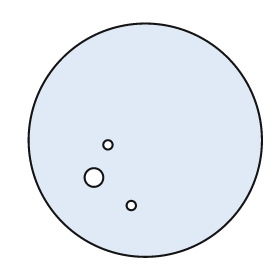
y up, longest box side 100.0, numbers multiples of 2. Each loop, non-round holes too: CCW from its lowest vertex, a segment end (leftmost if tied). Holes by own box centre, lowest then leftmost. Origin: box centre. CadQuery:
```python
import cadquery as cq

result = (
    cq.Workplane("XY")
    .moveTo(0.0, 0.0)
    .circle(50.0)
    .moveTo(-6.0, -28.0)
    .circle(2.0)
    .moveTo(-22.0, -16.0)
    .circle(4.0)
    .moveTo(-16.0, -2.0)
    .circle(2.0)
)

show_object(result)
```